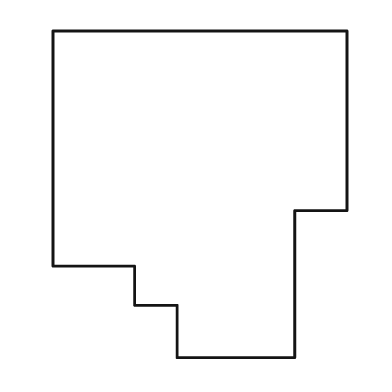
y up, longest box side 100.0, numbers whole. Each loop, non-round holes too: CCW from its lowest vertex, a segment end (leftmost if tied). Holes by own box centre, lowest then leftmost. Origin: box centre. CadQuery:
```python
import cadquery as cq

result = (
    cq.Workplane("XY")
    .moveTo(-7.0, -50.0)
    .lineTo(29.0, -50.0)
    .lineTo(29.0, -5.0)
    .lineTo(45.0, -5.0)
    .lineTo(45.0, 50.0)
    .lineTo(-45.0, 50.0)
    .lineTo(-45.0, -22.0)
    .lineTo(-20.0, -22.0)
    .lineTo(-20.0, -34.0)
    .lineTo(-7.0, -34.0)
    .close()
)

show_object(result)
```